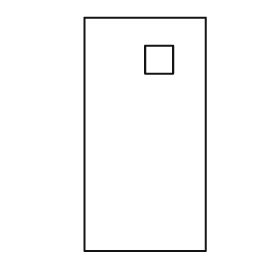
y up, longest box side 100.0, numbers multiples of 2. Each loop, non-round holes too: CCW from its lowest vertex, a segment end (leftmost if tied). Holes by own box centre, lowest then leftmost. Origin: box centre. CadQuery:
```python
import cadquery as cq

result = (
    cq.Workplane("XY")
    .moveTo(-26.0, -50.0)
    .lineTo(26.0, -50.0)
    .lineTo(26.0, 50.0)
    .lineTo(-26.0, 50.0)
    .close()
    .moveTo(0.0, 26.0)
    .lineTo(12.0, 26.0)
    .lineTo(12.0, 38.0)
    .lineTo(0.0, 38.0)
    .close()
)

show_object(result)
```